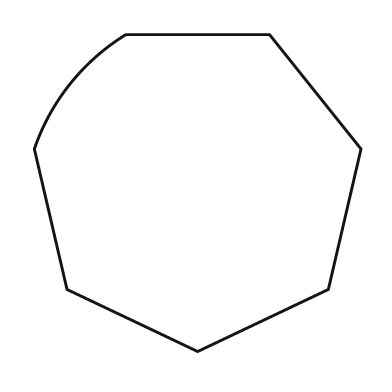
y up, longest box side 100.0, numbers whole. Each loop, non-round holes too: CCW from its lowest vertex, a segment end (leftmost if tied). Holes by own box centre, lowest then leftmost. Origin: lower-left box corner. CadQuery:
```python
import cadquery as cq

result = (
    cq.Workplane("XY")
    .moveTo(50.0, 0.0)
    .lineTo(90.0, 19.0)
    .lineTo(100.0, 62.0)
    .lineTo(72.0, 97.0)
    .lineTo(28.0, 97.0)
    .threePointArc((11.0, 82.0), (0.0, 62.0))
    .lineTo(10.0, 19.0)
    .close()
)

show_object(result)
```